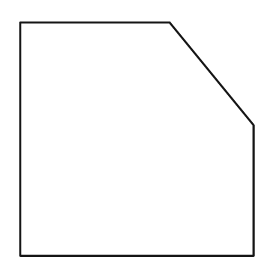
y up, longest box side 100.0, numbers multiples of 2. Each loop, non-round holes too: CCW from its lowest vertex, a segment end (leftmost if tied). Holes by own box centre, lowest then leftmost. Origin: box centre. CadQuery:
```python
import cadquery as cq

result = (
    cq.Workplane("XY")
    .moveTo(-50.0, -50.0)
    .lineTo(50.0, -50.0)
    .lineTo(50.0, 6.0)
    .lineTo(14.0, 50.0)
    .lineTo(-50.0, 50.0)
    .close()
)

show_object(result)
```